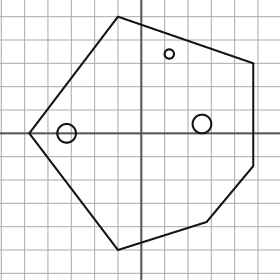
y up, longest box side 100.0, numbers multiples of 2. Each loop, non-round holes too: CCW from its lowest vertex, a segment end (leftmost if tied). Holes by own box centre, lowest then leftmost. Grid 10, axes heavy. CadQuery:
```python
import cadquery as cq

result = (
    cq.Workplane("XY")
    .moveTo(-10.0, -50.0)
    .lineTo(28.0, -38.0)
    .lineTo(48.0, -14.0)
    .lineTo(48.0, 30.0)
    .lineTo(-10.0, 50.0)
    .lineTo(-48.0, 0.0)
    .close()
    .moveTo(-32.0, 0.0)
    .circle(4.0)
    .moveTo(26.0, 4.0)
    .circle(4.0)
    .moveTo(12.0, 34.0)
    .circle(2.0)
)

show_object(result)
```